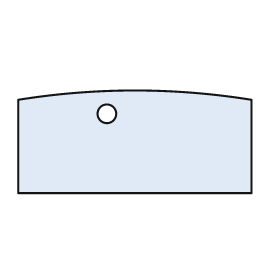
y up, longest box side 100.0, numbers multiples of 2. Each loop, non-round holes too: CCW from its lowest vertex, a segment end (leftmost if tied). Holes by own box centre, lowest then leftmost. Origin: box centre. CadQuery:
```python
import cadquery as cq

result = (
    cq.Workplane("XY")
    .moveTo(-50.0, -22.0)
    .lineTo(50.0, -22.0)
    .lineTo(50.0, 18.0)
    .threePointArc((0.0, 22.0), (-50.0, 18.0))
    .close()
    .moveTo(-12.0, 12.0)
    .circle(4.0)
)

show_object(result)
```